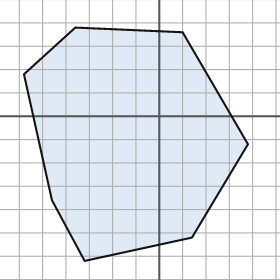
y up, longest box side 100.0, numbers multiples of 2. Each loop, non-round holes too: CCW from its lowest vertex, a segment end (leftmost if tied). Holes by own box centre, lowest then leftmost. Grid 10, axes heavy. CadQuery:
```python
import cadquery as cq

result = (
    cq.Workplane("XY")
    .moveTo(-32.0, -62.0)
    .lineTo(14.0, -52.0)
    .lineTo(38.0, -12.0)
    .lineTo(10.0, 36.0)
    .lineTo(-36.0, 38.0)
    .lineTo(-58.0, 18.0)
    .lineTo(-46.0, -36.0)
    .close()
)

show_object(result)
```